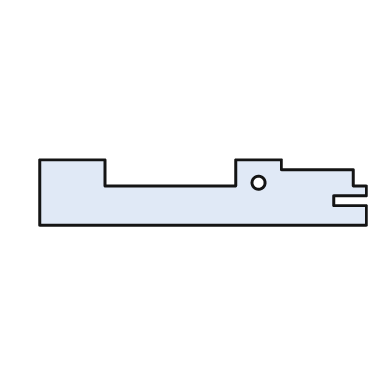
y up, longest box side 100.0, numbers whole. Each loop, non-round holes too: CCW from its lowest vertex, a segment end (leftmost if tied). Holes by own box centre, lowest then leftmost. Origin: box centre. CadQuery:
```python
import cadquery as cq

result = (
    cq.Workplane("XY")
    .moveTo(-50.0, -10.0)
    .lineTo(50.0, -10.0)
    .lineTo(50.0, -4.0)
    .lineTo(40.0, -4.0)
    .lineTo(40.0, -1.0)
    .lineTo(50.0, -1.0)
    .lineTo(50.0, 2.0)
    .lineTo(46.0, 2.0)
    .lineTo(46.0, 7.0)
    .lineTo(24.0, 7.0)
    .lineTo(24.0, 10.0)
    .lineTo(10.0, 10.0)
    .lineTo(10.0, 2.0)
    .lineTo(-30.0, 2.0)
    .lineTo(-30.0, 10.0)
    .lineTo(-50.0, 10.0)
    .close()
    .moveTo(17.0, 3.0)
    .circle(2.0)
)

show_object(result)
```